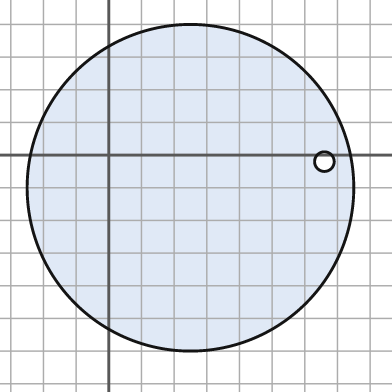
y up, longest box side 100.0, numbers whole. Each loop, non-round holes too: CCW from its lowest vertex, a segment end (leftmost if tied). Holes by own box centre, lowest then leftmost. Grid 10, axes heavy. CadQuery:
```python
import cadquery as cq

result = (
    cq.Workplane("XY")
    .moveTo(25.0, -10.0)
    .circle(50.0)
    .moveTo(66.0, -2.0)
    .circle(3.0)
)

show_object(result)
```